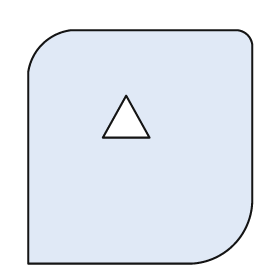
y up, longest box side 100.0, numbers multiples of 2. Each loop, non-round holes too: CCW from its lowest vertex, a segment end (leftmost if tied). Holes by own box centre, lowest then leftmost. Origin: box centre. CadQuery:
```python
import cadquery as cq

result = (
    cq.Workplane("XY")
    .moveTo(-48.0, -50.0)
    .lineTo(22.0, -50.0)
    .threePointArc((40.0, -42.0), (48.0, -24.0))
    .lineTo(48.0, 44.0)
    .threePointArc((46.0, 48.0), (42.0, 50.0))
    .lineTo(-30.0, 50.0)
    .threePointArc((-42.0, 44.0), (-48.0, 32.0))
    .close()
    .moveTo(-16.0, 4.0)
    .lineTo(4.0, 4.0)
    .lineTo(-6.0, 22.0)
    .close()
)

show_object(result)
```